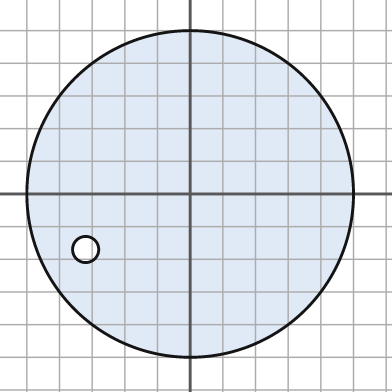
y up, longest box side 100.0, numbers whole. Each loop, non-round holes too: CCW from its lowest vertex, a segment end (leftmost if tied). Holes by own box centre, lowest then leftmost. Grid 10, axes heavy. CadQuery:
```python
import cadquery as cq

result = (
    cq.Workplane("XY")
    .moveTo(0.0, 0.0)
    .circle(50.0)
    .moveTo(-32.0, -17.0)
    .circle(4.0)
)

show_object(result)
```